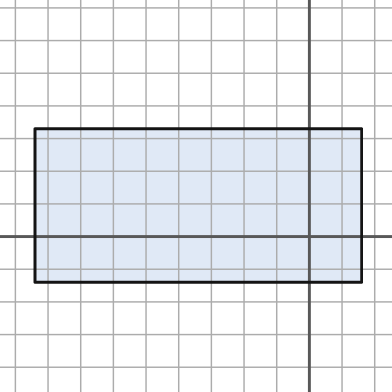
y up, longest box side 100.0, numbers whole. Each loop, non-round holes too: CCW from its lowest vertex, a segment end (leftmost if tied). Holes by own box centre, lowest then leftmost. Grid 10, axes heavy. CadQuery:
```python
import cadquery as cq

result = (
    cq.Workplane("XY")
    .moveTo(-84.0, -14.0)
    .lineTo(16.0, -14.0)
    .lineTo(16.0, 33.0)
    .lineTo(-84.0, 33.0)
    .close()
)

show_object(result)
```